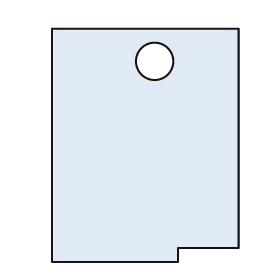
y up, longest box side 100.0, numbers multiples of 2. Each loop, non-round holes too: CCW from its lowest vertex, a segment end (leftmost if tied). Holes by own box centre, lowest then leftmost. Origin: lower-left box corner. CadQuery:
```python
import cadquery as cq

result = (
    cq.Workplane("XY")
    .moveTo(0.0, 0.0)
    .lineTo(54.0, 0.0)
    .lineTo(54.0, 6.0)
    .lineTo(80.0, 6.0)
    .lineTo(80.0, 100.0)
    .lineTo(0.0, 100.0)
    .close()
    .moveTo(44.0, 86.0)
    .circle(8.0)
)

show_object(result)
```